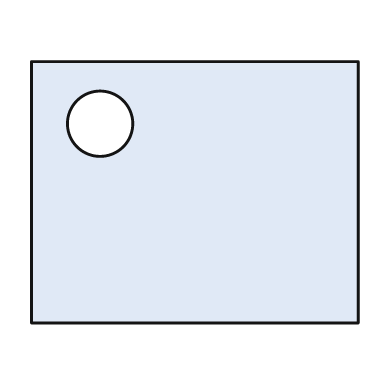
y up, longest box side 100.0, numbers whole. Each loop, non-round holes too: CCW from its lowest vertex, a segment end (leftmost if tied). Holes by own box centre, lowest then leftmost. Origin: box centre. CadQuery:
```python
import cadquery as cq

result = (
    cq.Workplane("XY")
    .moveTo(-50.0, -40.0)
    .lineTo(50.0, -40.0)
    .lineTo(50.0, 40.0)
    .lineTo(-50.0, 40.0)
    .close()
    .moveTo(-29.0, 21.0)
    .circle(10.0)
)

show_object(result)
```